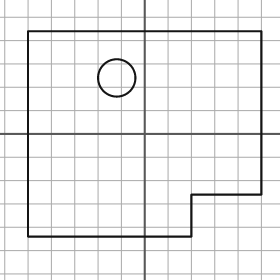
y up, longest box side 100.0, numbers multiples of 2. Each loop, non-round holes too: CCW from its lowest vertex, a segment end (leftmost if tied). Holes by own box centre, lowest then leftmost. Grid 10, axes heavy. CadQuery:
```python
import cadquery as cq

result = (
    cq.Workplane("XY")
    .moveTo(-50.0, -44.0)
    .lineTo(20.0, -44.0)
    .lineTo(20.0, -26.0)
    .lineTo(50.0, -26.0)
    .lineTo(50.0, 44.0)
    .lineTo(-50.0, 44.0)
    .close()
    .moveTo(-12.0, 24.0)
    .circle(8.0)
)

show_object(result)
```